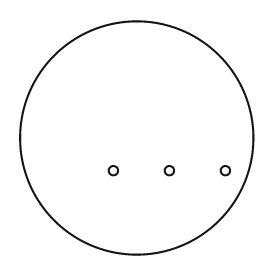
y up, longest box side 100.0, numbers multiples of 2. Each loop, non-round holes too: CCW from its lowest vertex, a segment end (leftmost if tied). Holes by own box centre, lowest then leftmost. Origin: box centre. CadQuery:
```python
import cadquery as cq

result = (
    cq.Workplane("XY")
    .moveTo(0.0, 0.0)
    .circle(50.0)
    .moveTo(-10.0, -14.0)
    .circle(2.0)
    .moveTo(14.0, -14.0)
    .circle(2.0)
    .moveTo(38.0, -14.0)
    .circle(2.0)
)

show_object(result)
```